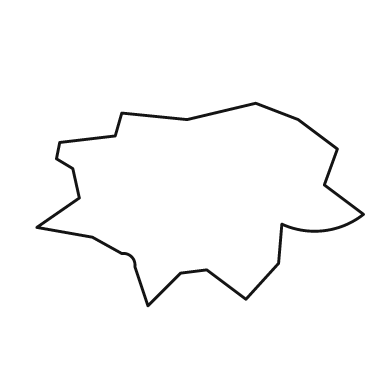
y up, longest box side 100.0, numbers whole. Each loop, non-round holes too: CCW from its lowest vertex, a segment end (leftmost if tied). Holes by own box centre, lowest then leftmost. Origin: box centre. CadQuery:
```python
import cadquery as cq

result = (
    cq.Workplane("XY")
    .moveTo(-16.0, -31.0)
    .lineTo(-6.0, -21.0)
    .lineTo(2.0, -20.0)
    .lineTo(14.0, -29.0)
    .lineTo(24.0, -18.0)
    .lineTo(25.0, -6.0)
    .threePointArc((38.0, -8.0), (50.0, -3.0))
    .lineTo(38.0, 6.0)
    .lineTo(42.0, 17.0)
    .lineTo(30.0, 26.0)
    .lineTo(17.0, 31.0)
    .lineTo(-4.0, 26.0)
    .lineTo(-24.0, 28.0)
    .lineTo(-26.0, 21.0)
    .lineTo(-43.0, 19.0)
    .lineTo(-44.0, 14.0)
    .lineTo(-39.0, 11.0)
    .lineTo(-37.0, 2.0)
    .lineTo(-50.0, -7.0)
    .lineTo(-33.0, -10.0)
    .lineTo(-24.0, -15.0)
    .threePointArc((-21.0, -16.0), (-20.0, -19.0))
    .close()
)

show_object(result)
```